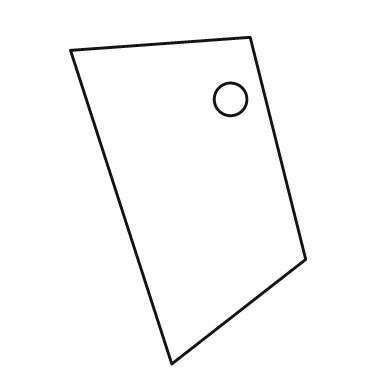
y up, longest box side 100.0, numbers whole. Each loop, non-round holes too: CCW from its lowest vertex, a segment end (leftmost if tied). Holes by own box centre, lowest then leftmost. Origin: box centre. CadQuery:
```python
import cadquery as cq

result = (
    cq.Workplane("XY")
    .moveTo(-5.0, -50.0)
    .lineTo(36.0, -18.0)
    .lineTo(19.0, 50.0)
    .lineTo(-36.0, 46.0)
    .close()
    .moveTo(13.0, 31.0)
    .circle(5.0)
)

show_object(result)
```